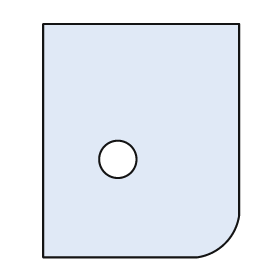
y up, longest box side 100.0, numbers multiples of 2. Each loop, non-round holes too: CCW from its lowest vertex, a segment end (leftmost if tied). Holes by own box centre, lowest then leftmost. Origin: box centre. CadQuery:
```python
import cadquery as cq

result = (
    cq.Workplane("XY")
    .moveTo(-42.0, -50.0)
    .lineTo(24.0, -50.0)
    .threePointArc((36.0, -44.0), (42.0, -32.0))
    .lineTo(42.0, 50.0)
    .lineTo(-42.0, 50.0)
    .close()
    .moveTo(-10.0, -8.0)
    .circle(8.0)
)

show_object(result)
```